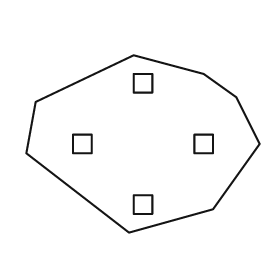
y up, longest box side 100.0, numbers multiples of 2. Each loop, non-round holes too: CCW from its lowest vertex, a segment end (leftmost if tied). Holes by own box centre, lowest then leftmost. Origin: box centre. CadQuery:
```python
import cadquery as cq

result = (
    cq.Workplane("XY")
    .moveTo(-6.0, -38.0)
    .lineTo(30.0, -28.0)
    .lineTo(50.0, 0.0)
    .lineTo(40.0, 20.0)
    .lineTo(26.0, 30.0)
    .lineTo(-4.0, 38.0)
    .lineTo(-46.0, 18.0)
    .lineTo(-50.0, -4.0)
    .close()
    .moveTo(-4.0, -30.0)
    .lineTo(4.0, -30.0)
    .lineTo(4.0, -22.0)
    .lineTo(-4.0, -22.0)
    .close()
    .moveTo(-30.0, -4.0)
    .lineTo(-22.0, -4.0)
    .lineTo(-22.0, 4.0)
    .lineTo(-30.0, 4.0)
    .close()
    .moveTo(22.0, -4.0)
    .lineTo(30.0, -4.0)
    .lineTo(30.0, 4.0)
    .lineTo(22.0, 4.0)
    .close()
    .moveTo(-4.0, 22.0)
    .lineTo(4.0, 22.0)
    .lineTo(4.0, 30.0)
    .lineTo(-4.0, 30.0)
    .close()
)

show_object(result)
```